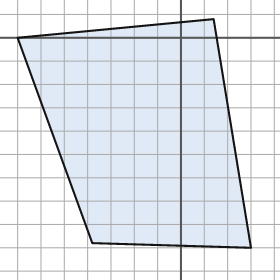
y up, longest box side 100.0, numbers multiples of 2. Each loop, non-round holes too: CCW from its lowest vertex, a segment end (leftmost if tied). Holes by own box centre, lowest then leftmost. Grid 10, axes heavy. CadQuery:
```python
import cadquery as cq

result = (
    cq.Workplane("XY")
    .moveTo(30.0, -90.0)
    .lineTo(14.0, 8.0)
    .lineTo(-70.0, 0.0)
    .lineTo(-38.0, -88.0)
    .close()
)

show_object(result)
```